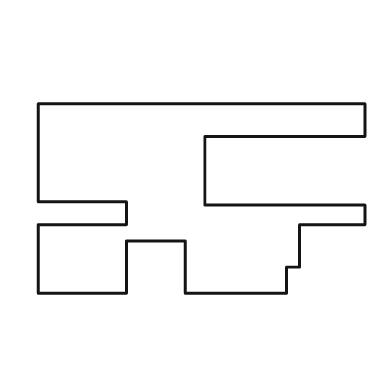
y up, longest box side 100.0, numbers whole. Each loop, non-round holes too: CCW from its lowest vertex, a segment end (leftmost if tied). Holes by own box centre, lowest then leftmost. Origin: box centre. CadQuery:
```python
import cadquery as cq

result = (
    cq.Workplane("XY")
    .moveTo(-50.0, -29.0)
    .lineTo(-23.0, -29.0)
    .lineTo(-23.0, -13.0)
    .lineTo(-5.0, -13.0)
    .lineTo(-5.0, -29.0)
    .lineTo(26.0, -29.0)
    .lineTo(26.0, -21.0)
    .lineTo(30.0, -21.0)
    .lineTo(30.0, -8.0)
    .lineTo(50.0, -8.0)
    .lineTo(50.0, -2.0)
    .lineTo(1.0, -2.0)
    .lineTo(1.0, 19.0)
    .lineTo(50.0, 19.0)
    .lineTo(50.0, 29.0)
    .lineTo(-50.0, 29.0)
    .lineTo(-50.0, -1.0)
    .lineTo(-23.0, -1.0)
    .lineTo(-23.0, -8.0)
    .lineTo(-50.0, -8.0)
    .close()
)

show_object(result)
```